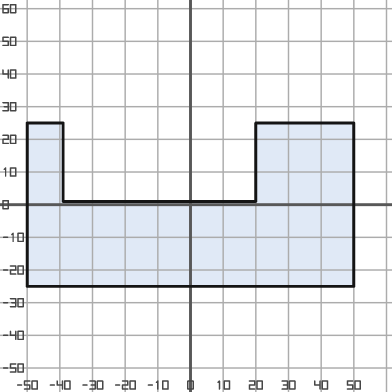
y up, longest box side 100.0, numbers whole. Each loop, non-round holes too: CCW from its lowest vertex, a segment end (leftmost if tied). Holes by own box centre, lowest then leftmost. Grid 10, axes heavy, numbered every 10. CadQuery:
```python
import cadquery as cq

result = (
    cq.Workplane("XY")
    .moveTo(-50.0, -25.0)
    .lineTo(50.0, -25.0)
    .lineTo(50.0, 25.0)
    .lineTo(20.0, 25.0)
    .lineTo(20.0, 1.0)
    .lineTo(-39.0, 1.0)
    .lineTo(-39.0, 25.0)
    .lineTo(-50.0, 25.0)
    .close()
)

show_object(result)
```